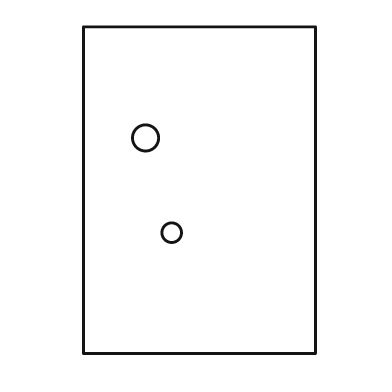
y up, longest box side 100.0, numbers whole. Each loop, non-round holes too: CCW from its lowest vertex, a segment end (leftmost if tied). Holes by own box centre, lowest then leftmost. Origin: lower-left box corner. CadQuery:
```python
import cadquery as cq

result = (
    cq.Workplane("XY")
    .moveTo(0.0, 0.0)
    .lineTo(71.0, 0.0)
    .lineTo(71.0, 100.0)
    .lineTo(0.0, 100.0)
    .close()
    .moveTo(27.0, 37.0)
    .circle(3.0)
    .moveTo(19.0, 66.0)
    .circle(4.0)
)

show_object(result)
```